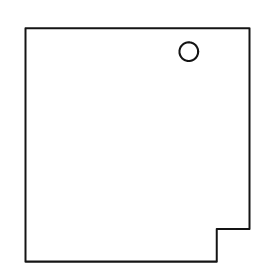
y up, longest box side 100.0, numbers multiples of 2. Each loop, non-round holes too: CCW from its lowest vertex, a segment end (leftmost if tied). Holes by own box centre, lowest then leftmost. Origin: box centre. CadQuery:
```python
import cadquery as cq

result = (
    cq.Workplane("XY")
    .moveTo(-48.0, -50.0)
    .lineTo(34.0, -50.0)
    .lineTo(34.0, -36.0)
    .lineTo(48.0, -36.0)
    .lineTo(48.0, 50.0)
    .lineTo(-48.0, 50.0)
    .close()
    .moveTo(22.0, 40.0)
    .circle(4.0)
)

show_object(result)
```